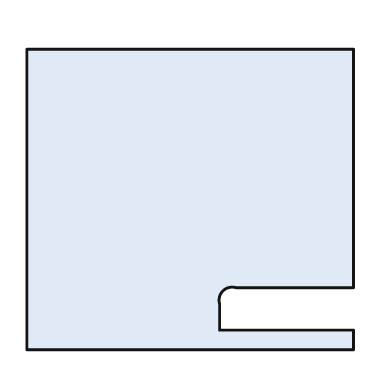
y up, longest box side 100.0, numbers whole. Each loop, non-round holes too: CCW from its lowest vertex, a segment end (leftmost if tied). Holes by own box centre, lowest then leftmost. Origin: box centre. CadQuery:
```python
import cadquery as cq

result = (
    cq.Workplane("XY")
    .moveTo(-50.0, -46.0)
    .lineTo(50.0, -46.0)
    .lineTo(50.0, -40.0)
    .lineTo(9.0, -40.0)
    .lineTo(9.0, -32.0)
    .threePointArc((10.0, -28.0), (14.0, -27.0))
    .lineTo(50.0, -27.0)
    .lineTo(50.0, 46.0)
    .lineTo(-50.0, 46.0)
    .close()
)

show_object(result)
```